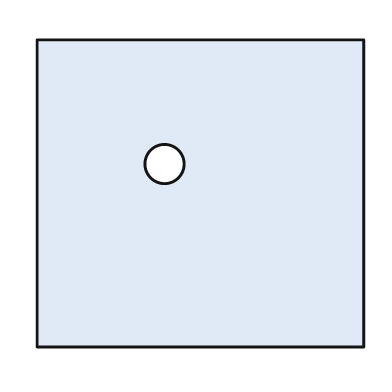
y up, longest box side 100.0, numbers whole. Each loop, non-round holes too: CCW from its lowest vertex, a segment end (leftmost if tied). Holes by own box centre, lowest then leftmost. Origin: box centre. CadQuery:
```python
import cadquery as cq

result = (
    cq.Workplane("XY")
    .moveTo(-50.0, -47.0)
    .lineTo(50.0, -47.0)
    .lineTo(50.0, 47.0)
    .lineTo(-50.0, 47.0)
    .close()
    .moveTo(-11.0, 9.0)
    .circle(6.0)
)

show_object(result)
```